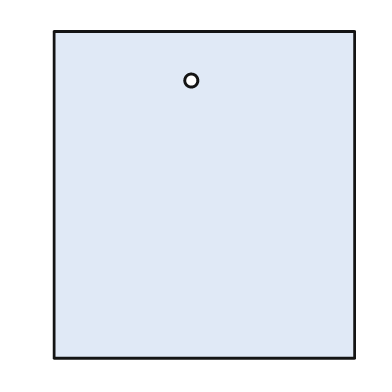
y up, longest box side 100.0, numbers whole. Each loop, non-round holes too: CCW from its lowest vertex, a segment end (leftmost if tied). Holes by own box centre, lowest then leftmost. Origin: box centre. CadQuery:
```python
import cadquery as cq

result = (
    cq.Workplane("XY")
    .moveTo(-46.0, -50.0)
    .lineTo(46.0, -50.0)
    .lineTo(46.0, 50.0)
    .lineTo(-46.0, 50.0)
    .close()
    .moveTo(-4.0, 35.0)
    .circle(2.0)
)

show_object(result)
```